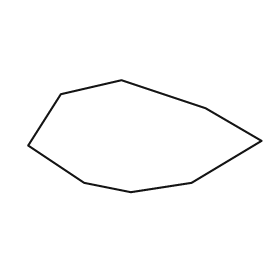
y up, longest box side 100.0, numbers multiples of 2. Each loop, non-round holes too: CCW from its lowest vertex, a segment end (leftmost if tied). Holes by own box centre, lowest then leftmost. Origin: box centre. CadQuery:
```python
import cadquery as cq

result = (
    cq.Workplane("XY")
    .moveTo(-6.0, -24.0)
    .lineTo(20.0, -20.0)
    .lineTo(50.0, -2.0)
    .lineTo(26.0, 12.0)
    .lineTo(-10.0, 24.0)
    .lineTo(-36.0, 18.0)
    .lineTo(-50.0, -4.0)
    .lineTo(-26.0, -20.0)
    .close()
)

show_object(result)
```